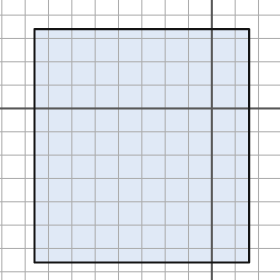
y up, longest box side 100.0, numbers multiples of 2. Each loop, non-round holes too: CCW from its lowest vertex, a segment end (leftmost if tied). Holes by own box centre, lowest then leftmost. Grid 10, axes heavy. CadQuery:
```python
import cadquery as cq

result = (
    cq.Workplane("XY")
    .moveTo(-76.0, -66.0)
    .lineTo(16.0, -66.0)
    .lineTo(16.0, 34.0)
    .lineTo(-76.0, 34.0)
    .close()
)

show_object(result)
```